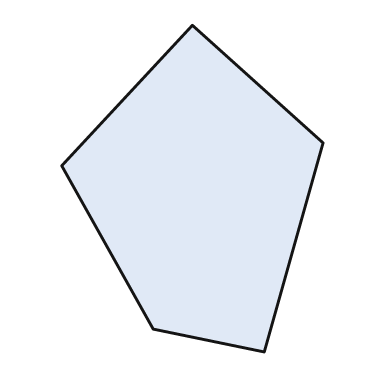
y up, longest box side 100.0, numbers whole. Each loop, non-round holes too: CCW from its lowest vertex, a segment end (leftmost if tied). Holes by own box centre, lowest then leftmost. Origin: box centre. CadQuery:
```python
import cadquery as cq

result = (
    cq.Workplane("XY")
    .moveTo(22.0, -50.0)
    .lineTo(40.0, 14.0)
    .lineTo(0.0, 50.0)
    .lineTo(-40.0, 7.0)
    .lineTo(-12.0, -43.0)
    .close()
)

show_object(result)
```